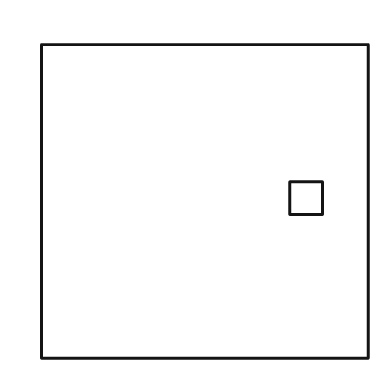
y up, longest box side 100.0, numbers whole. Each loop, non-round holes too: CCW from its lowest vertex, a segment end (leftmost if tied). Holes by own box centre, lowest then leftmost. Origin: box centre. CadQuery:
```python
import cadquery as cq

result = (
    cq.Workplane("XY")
    .moveTo(-50.0, -48.0)
    .lineTo(50.0, -48.0)
    .lineTo(50.0, 48.0)
    .lineTo(-50.0, 48.0)
    .close()
    .moveTo(26.0, -4.0)
    .lineTo(36.0, -4.0)
    .lineTo(36.0, 6.0)
    .lineTo(26.0, 6.0)
    .close()
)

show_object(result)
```